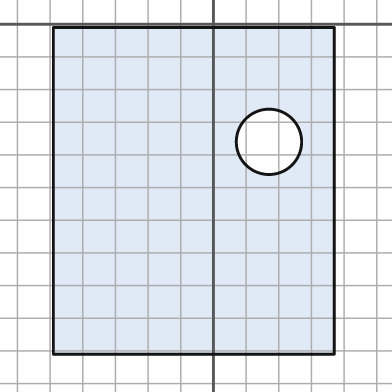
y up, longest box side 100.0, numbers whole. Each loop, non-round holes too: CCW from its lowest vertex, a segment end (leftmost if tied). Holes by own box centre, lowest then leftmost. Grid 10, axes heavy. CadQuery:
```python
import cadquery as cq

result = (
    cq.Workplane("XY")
    .moveTo(-49.0, -101.0)
    .lineTo(37.0, -101.0)
    .lineTo(37.0, -1.0)
    .lineTo(-49.0, -1.0)
    .close()
    .moveTo(17.0, -36.0)
    .circle(10.0)
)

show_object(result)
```